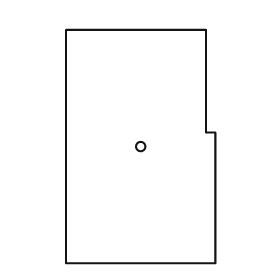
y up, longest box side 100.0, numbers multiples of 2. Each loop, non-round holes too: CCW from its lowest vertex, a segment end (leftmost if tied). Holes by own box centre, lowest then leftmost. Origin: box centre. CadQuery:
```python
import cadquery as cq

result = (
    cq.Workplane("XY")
    .moveTo(-32.0, -50.0)
    .lineTo(32.0, -50.0)
    .lineTo(32.0, 6.0)
    .lineTo(28.0, 6.0)
    .lineTo(28.0, 50.0)
    .lineTo(-32.0, 50.0)
    .close()
    .moveTo(0.0, 0.0)
    .circle(2.0)
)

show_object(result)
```